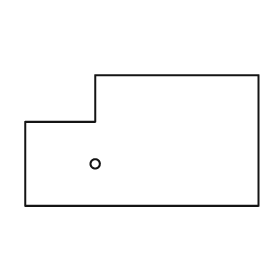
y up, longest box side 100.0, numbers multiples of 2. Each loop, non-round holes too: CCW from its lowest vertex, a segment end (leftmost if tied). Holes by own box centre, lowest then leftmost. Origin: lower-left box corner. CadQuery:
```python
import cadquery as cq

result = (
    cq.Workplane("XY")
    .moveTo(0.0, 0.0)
    .lineTo(100.0, 0.0)
    .lineTo(100.0, 56.0)
    .lineTo(30.0, 56.0)
    .lineTo(30.0, 36.0)
    .lineTo(0.0, 36.0)
    .close()
    .moveTo(30.0, 18.0)
    .circle(2.0)
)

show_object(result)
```